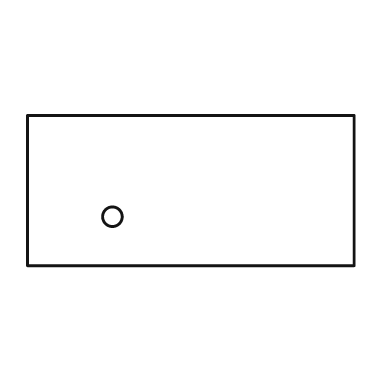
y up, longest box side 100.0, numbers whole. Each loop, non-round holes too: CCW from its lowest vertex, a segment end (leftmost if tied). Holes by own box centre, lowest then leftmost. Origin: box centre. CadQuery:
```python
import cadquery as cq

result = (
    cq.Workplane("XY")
    .moveTo(-50.0, -23.0)
    .lineTo(50.0, -23.0)
    .lineTo(50.0, 23.0)
    .lineTo(-50.0, 23.0)
    .close()
    .moveTo(-24.0, -8.0)
    .circle(3.0)
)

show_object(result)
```